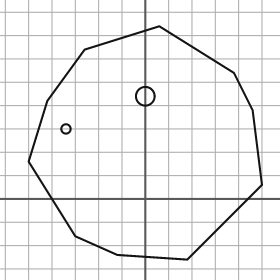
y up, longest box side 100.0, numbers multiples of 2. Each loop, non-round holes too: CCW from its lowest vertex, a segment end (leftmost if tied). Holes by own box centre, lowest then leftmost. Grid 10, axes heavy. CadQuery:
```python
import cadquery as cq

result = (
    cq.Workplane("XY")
    .moveTo(18.0, -26.0)
    .lineTo(50.0, 6.0)
    .lineTo(46.0, 38.0)
    .lineTo(38.0, 54.0)
    .lineTo(6.0, 74.0)
    .lineTo(-26.0, 64.0)
    .lineTo(-42.0, 42.0)
    .lineTo(-50.0, 16.0)
    .lineTo(-30.0, -16.0)
    .lineTo(-12.0, -24.0)
    .close()
    .moveTo(-34.0, 30.0)
    .circle(2.0)
    .moveTo(0.0, 44.0)
    .circle(4.0)
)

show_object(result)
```